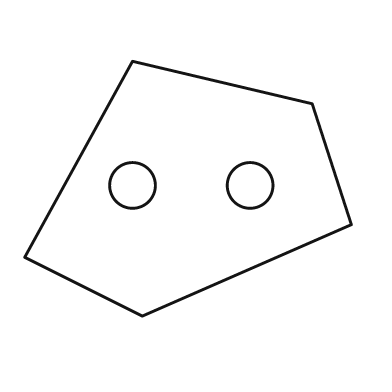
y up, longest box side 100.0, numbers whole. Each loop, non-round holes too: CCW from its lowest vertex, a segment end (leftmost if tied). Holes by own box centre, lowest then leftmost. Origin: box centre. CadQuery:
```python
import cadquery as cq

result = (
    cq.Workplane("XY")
    .moveTo(-14.0, -39.0)
    .lineTo(50.0, -11.0)
    .lineTo(38.0, 26.0)
    .lineTo(-17.0, 39.0)
    .lineTo(-50.0, -21.0)
    .close()
    .moveTo(-17.0, 1.0)
    .circle(7.0)
    .moveTo(19.0, 1.0)
    .circle(7.0)
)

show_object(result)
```